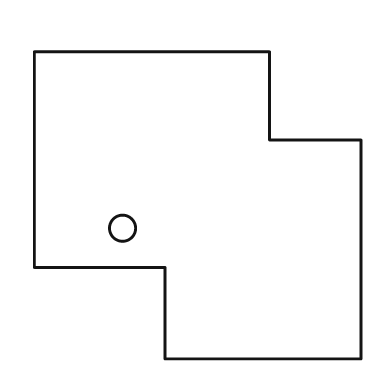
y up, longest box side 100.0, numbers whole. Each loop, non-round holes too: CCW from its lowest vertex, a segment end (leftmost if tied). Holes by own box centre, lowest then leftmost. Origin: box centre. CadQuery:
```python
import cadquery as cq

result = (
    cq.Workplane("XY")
    .moveTo(-10.0, -47.0)
    .lineTo(50.0, -47.0)
    .lineTo(50.0, 20.0)
    .lineTo(22.0, 20.0)
    .lineTo(22.0, 47.0)
    .lineTo(-50.0, 47.0)
    .lineTo(-50.0, -19.0)
    .lineTo(-10.0, -19.0)
    .close()
    .moveTo(-23.0, -7.0)
    .circle(4.0)
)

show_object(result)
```